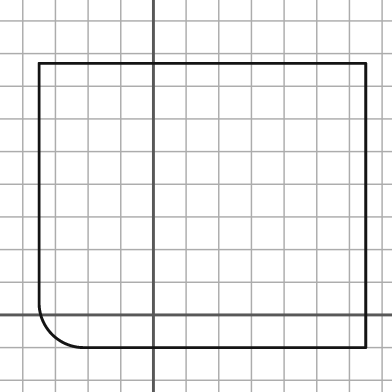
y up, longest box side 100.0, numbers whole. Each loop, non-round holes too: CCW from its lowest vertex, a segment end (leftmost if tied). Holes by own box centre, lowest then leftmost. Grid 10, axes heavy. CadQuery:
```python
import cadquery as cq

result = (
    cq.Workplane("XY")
    .moveTo(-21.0, -10.0)
    .lineTo(65.0, -10.0)
    .lineTo(65.0, 77.0)
    .lineTo(-35.0, 77.0)
    .lineTo(-35.0, 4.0)
    .threePointArc((-31.0, -6.0), (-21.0, -10.0))
    .close()
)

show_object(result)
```